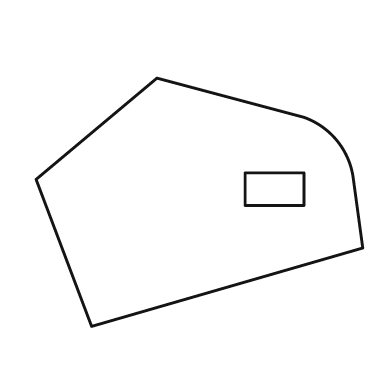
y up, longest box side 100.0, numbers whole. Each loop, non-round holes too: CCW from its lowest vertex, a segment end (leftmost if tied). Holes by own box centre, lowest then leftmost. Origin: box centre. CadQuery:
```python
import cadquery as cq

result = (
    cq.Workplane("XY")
    .moveTo(-33.0, -38.0)
    .lineTo(50.0, -14.0)
    .lineTo(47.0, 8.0)
    .threePointArc((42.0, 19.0), (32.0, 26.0))
    .lineTo(-13.0, 38.0)
    .lineTo(-50.0, 7.0)
    .close()
    .moveTo(14.0, -1.0)
    .lineTo(32.0, -1.0)
    .lineTo(32.0, 9.0)
    .lineTo(14.0, 9.0)
    .close()
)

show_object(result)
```